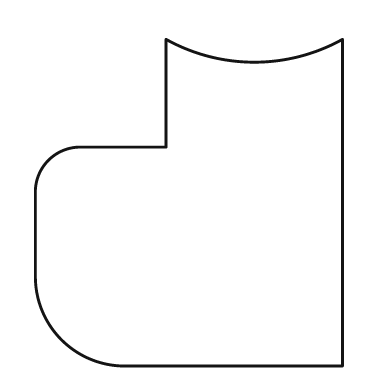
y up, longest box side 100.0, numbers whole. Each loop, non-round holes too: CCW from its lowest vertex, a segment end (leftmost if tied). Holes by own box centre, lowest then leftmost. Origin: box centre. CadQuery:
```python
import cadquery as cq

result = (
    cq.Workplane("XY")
    .moveTo(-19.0, -50.0)
    .lineTo(47.0, -50.0)
    .lineTo(47.0, 50.0)
    .threePointArc((20.0, 43.0), (-7.0, 50.0))
    .lineTo(-7.0, 17.0)
    .lineTo(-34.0, 17.0)
    .threePointArc((-43.0, 13.0), (-47.0, 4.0))
    .lineTo(-47.0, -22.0)
    .threePointArc((-39.0, -42.0), (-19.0, -50.0))
    .close()
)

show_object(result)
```